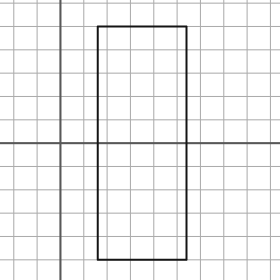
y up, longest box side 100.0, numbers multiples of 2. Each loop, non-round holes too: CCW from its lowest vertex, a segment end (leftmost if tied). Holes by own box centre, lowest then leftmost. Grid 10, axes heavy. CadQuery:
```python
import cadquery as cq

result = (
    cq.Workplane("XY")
    .moveTo(16.0, -50.0)
    .lineTo(54.0, -50.0)
    .lineTo(54.0, 50.0)
    .lineTo(16.0, 50.0)
    .close()
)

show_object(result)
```